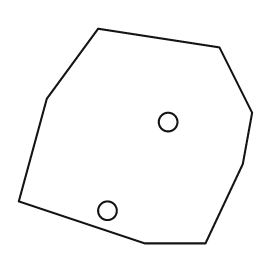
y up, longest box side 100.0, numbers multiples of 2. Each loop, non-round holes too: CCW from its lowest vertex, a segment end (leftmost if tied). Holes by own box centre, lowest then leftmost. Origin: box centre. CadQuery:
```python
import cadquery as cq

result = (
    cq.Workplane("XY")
    .moveTo(4.0, -46.0)
    .lineTo(30.0, -46.0)
    .lineTo(46.0, -12.0)
    .lineTo(50.0, 10.0)
    .lineTo(36.0, 38.0)
    .lineTo(-16.0, 46.0)
    .lineTo(-38.0, 16.0)
    .lineTo(-50.0, -28.0)
    .close()
    .moveTo(-12.0, -32.0)
    .circle(4.0)
    .moveTo(14.0, 6.0)
    .circle(4.0)
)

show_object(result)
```